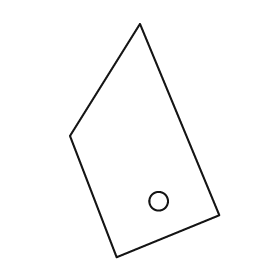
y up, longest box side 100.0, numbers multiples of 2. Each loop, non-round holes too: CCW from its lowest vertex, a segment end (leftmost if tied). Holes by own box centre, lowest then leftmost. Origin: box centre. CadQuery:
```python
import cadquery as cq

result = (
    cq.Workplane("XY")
    .moveTo(-12.0, -50.0)
    .lineTo(32.0, -32.0)
    .lineTo(-2.0, 50.0)
    .lineTo(-32.0, 2.0)
    .close()
    .moveTo(6.0, -26.0)
    .circle(4.0)
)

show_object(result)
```